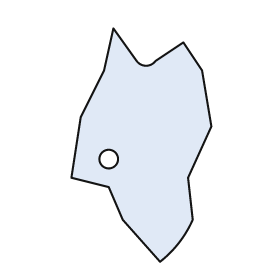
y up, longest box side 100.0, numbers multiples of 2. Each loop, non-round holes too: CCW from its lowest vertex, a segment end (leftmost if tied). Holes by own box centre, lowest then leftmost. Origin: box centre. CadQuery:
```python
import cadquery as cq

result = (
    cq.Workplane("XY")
    .moveTo(8.0, -50.0)
    .threePointArc((16.0, -42.0), (22.0, -32.0))
    .lineTo(20.0, -14.0)
    .lineTo(30.0, 8.0)
    .lineTo(26.0, 32.0)
    .lineTo(18.0, 44.0)
    .lineTo(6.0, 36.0)
    .threePointArc((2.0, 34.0), (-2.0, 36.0))
    .lineTo(-12.0, 50.0)
    .lineTo(-16.0, 32.0)
    .lineTo(-26.0, 12.0)
    .lineTo(-30.0, -14.0)
    .lineTo(-14.0, -18.0)
    .lineTo(-8.0, -32.0)
    .close()
    .moveTo(-14.0, -6.0)
    .circle(4.0)
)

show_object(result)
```